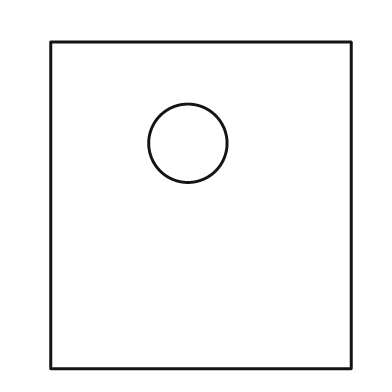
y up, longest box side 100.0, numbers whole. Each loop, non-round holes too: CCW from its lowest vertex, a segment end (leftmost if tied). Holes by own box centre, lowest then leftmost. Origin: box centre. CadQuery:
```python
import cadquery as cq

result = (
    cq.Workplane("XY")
    .moveTo(-46.0, -50.0)
    .lineTo(46.0, -50.0)
    .lineTo(46.0, 50.0)
    .lineTo(-46.0, 50.0)
    .close()
    .moveTo(-4.0, 19.0)
    .circle(12.0)
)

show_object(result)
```